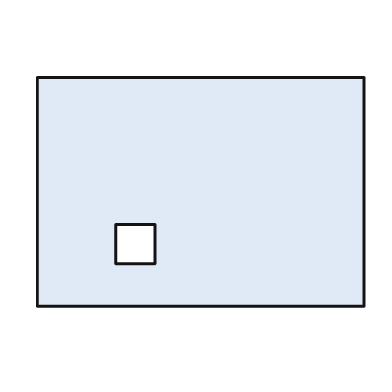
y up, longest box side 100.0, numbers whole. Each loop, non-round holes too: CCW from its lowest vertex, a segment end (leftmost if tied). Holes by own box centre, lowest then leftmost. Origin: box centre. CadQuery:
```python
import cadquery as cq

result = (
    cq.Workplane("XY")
    .moveTo(-50.0, -35.0)
    .lineTo(50.0, -35.0)
    .lineTo(50.0, 35.0)
    .lineTo(-50.0, 35.0)
    .close()
    .moveTo(-26.0, -22.0)
    .lineTo(-14.0, -22.0)
    .lineTo(-14.0, -10.0)
    .lineTo(-26.0, -10.0)
    .close()
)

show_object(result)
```